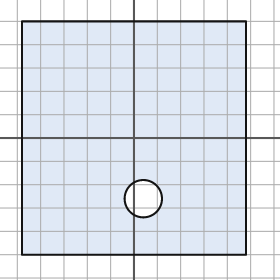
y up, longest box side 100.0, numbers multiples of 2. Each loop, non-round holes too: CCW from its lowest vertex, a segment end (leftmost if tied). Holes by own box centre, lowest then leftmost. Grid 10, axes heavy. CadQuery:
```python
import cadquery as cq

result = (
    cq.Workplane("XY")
    .moveTo(-48.0, -50.0)
    .lineTo(48.0, -50.0)
    .lineTo(48.0, 50.0)
    .lineTo(-48.0, 50.0)
    .close()
    .moveTo(4.0, -26.0)
    .circle(8.0)
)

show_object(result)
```